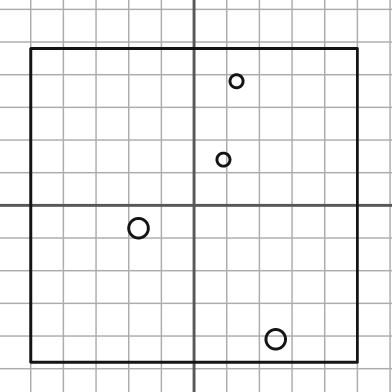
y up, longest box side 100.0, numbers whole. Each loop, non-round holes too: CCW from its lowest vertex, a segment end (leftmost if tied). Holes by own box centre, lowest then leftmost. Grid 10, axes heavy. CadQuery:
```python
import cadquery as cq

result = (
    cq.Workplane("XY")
    .moveTo(-50.0, -48.0)
    .lineTo(50.0, -48.0)
    .lineTo(50.0, 48.0)
    .lineTo(-50.0, 48.0)
    .close()
    .moveTo(25.0, -41.0)
    .circle(3.0)
    .moveTo(-17.0, -7.0)
    .circle(3.0)
    .moveTo(9.0, 14.0)
    .circle(2.0)
    .moveTo(13.0, 38.0)
    .circle(2.0)
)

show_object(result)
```